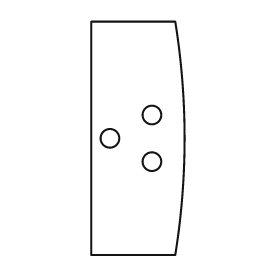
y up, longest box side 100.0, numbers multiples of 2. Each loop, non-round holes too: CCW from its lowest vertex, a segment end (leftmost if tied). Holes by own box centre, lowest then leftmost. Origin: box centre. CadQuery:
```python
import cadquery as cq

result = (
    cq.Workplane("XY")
    .moveTo(-20.0, -50.0)
    .lineTo(16.0, -50.0)
    .threePointArc((20.0, 0.0), (16.0, 50.0))
    .lineTo(-20.0, 50.0)
    .close()
    .moveTo(6.0, -10.0)
    .circle(4.0)
    .moveTo(-12.0, 0.0)
    .circle(4.0)
    .moveTo(6.0, 10.0)
    .circle(4.0)
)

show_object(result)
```